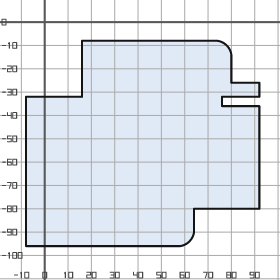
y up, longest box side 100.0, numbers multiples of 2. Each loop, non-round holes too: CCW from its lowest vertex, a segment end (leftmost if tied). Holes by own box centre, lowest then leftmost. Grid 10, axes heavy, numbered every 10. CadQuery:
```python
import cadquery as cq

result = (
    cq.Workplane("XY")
    .moveTo(-8.0, -96.0)
    .lineTo(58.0, -96.0)
    .threePointArc((62.0, -94.0), (64.0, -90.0))
    .lineTo(64.0, -80.0)
    .lineTo(92.0, -80.0)
    .lineTo(92.0, -36.0)
    .lineTo(76.0, -36.0)
    .lineTo(76.0, -32.0)
    .lineTo(92.0, -32.0)
    .lineTo(92.0, -26.0)
    .lineTo(80.0, -26.0)
    .lineTo(80.0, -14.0)
    .threePointArc((78.0, -10.0), (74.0, -8.0))
    .lineTo(16.0, -8.0)
    .lineTo(16.0, -32.0)
    .lineTo(-8.0, -32.0)
    .close()
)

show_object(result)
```